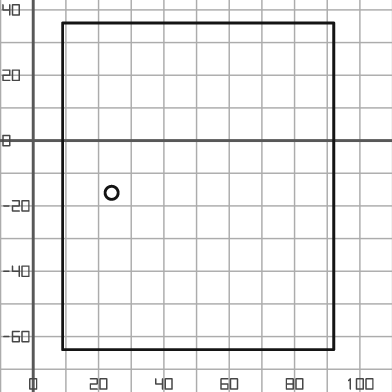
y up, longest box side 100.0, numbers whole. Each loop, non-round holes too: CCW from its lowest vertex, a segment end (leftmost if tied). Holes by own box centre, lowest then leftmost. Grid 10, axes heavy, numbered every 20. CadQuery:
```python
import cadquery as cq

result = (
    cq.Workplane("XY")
    .moveTo(9.0, -64.0)
    .lineTo(92.0, -64.0)
    .lineTo(92.0, 36.0)
    .lineTo(9.0, 36.0)
    .close()
    .moveTo(24.0, -16.0)
    .circle(2.0)
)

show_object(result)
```